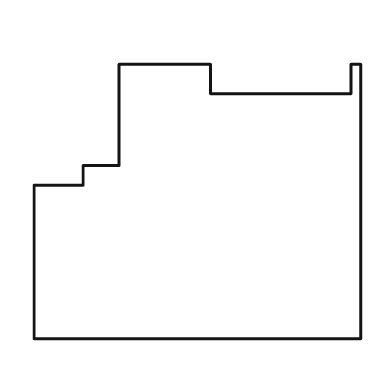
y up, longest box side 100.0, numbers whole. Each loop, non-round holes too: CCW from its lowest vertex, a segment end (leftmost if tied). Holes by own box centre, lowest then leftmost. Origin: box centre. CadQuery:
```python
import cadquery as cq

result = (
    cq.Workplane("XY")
    .moveTo(-50.0, -42.0)
    .lineTo(50.0, -42.0)
    .lineTo(50.0, 42.0)
    .lineTo(47.0, 42.0)
    .lineTo(47.0, 33.0)
    .lineTo(4.0, 33.0)
    .lineTo(4.0, 42.0)
    .lineTo(-24.0, 42.0)
    .lineTo(-24.0, 11.0)
    .lineTo(-35.0, 11.0)
    .lineTo(-35.0, 5.0)
    .lineTo(-50.0, 5.0)
    .close()
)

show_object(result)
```